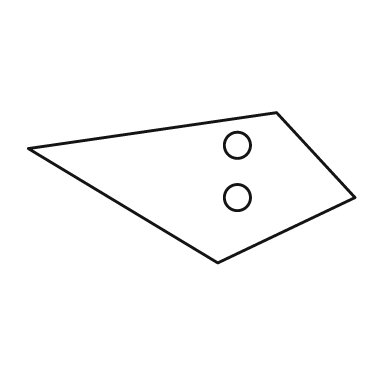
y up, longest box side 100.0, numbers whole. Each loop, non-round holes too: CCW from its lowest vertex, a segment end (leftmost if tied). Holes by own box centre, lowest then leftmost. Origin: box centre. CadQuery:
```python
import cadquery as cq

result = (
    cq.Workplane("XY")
    .moveTo(8.0, -23.0)
    .lineTo(50.0, -3.0)
    .lineTo(26.0, 23.0)
    .lineTo(-50.0, 12.0)
    .close()
    .moveTo(14.0, -3.0)
    .circle(4.0)
    .moveTo(14.0, 13.0)
    .circle(4.0)
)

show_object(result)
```